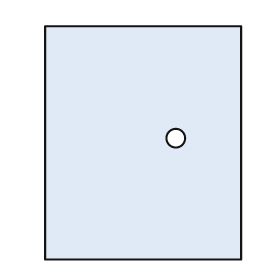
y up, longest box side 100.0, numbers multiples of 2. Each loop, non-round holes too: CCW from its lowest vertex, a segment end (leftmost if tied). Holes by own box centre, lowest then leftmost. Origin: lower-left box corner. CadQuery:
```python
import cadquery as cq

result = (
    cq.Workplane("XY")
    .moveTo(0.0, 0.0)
    .lineTo(84.0, 0.0)
    .lineTo(84.0, 100.0)
    .lineTo(0.0, 100.0)
    .close()
    .moveTo(56.0, 52.0)
    .circle(4.0)
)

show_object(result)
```